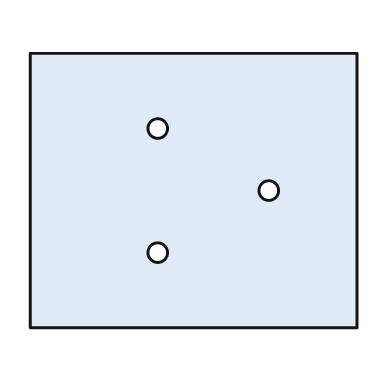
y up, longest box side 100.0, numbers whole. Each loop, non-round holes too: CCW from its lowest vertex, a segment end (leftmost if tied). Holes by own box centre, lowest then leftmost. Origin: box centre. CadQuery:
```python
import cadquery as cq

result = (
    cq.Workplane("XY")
    .moveTo(-50.0, -42.0)
    .lineTo(50.0, -42.0)
    .lineTo(50.0, 42.0)
    .lineTo(-50.0, 42.0)
    .close()
    .moveTo(-11.0, -19.0)
    .circle(3.0)
    .moveTo(23.0, 0.0)
    .circle(3.0)
    .moveTo(-11.0, 19.0)
    .circle(3.0)
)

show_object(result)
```